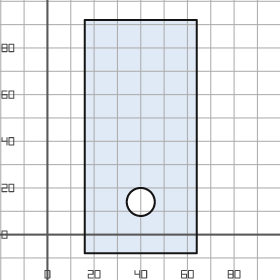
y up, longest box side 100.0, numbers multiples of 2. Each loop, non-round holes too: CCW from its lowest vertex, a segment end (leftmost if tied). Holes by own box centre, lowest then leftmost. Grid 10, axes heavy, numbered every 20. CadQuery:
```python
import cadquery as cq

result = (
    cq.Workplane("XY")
    .moveTo(16.0, -8.0)
    .lineTo(64.0, -8.0)
    .lineTo(64.0, 92.0)
    .lineTo(16.0, 92.0)
    .close()
    .moveTo(40.0, 14.0)
    .circle(6.0)
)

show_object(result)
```